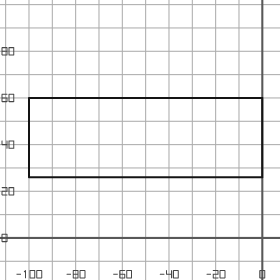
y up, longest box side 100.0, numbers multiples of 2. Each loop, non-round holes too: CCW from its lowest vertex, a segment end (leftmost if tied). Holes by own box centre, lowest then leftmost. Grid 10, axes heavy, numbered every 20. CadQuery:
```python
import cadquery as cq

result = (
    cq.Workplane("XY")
    .moveTo(-100.0, 26.0)
    .lineTo(0.0, 26.0)
    .lineTo(0.0, 60.0)
    .lineTo(-100.0, 60.0)
    .close()
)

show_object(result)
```